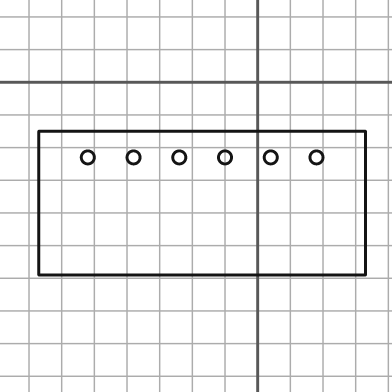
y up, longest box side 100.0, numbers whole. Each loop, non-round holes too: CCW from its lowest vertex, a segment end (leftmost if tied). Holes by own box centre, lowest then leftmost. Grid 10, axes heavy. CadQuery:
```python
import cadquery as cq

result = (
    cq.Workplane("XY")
    .moveTo(-67.0, -59.0)
    .lineTo(33.0, -59.0)
    .lineTo(33.0, -15.0)
    .lineTo(-67.0, -15.0)
    .close()
    .moveTo(-52.0, -23.0)
    .circle(2.0)
    .moveTo(-38.0, -23.0)
    .circle(2.0)
    .moveTo(-24.0, -23.0)
    .circle(2.0)
    .moveTo(-10.0, -23.0)
    .circle(2.0)
    .moveTo(4.0, -23.0)
    .circle(2.0)
    .moveTo(18.0, -23.0)
    .circle(2.0)
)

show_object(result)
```